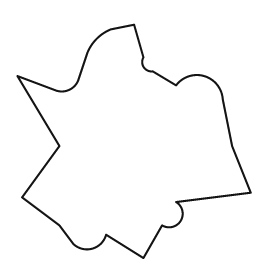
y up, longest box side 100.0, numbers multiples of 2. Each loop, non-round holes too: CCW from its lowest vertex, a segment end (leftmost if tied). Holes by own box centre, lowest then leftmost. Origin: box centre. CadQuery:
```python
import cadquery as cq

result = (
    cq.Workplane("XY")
    .moveTo(4.0, -50.0)
    .lineTo(12.0, -36.0)
    .threePointArc((20.0, -34.0), (18.0, -26.0))
    .lineTo(50.0, -22.0)
    .lineTo(42.0, -2.0)
    .lineTo(38.0, 18.0)
    .threePointArc((30.0, 28.0), (18.0, 24.0))
    .lineTo(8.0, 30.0)
    .threePointArc((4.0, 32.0), (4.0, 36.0))
    .lineTo(0.0, 50.0)
    .lineTo(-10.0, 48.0)
    .threePointArc((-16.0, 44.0), (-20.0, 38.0))
    .lineTo(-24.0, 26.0)
    .threePointArc((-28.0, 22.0), (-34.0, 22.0))
    .lineTo(-50.0, 28.0)
    .lineTo(-32.0, -2.0)
    .lineTo(-48.0, -24.0)
    .lineTo(-32.0, -36.0)
    .lineTo(-26.0, -44.0)
    .threePointArc((-18.0, -46.0), (-12.0, -40.0))
    .close()
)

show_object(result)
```